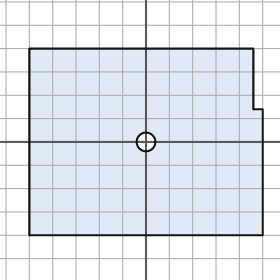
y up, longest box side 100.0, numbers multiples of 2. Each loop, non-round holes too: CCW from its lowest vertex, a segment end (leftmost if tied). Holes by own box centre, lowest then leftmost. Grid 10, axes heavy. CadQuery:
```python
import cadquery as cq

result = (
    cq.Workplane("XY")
    .moveTo(-50.0, -40.0)
    .lineTo(50.0, -40.0)
    .lineTo(50.0, 14.0)
    .lineTo(46.0, 14.0)
    .lineTo(46.0, 40.0)
    .lineTo(-50.0, 40.0)
    .close()
    .moveTo(0.0, 0.0)
    .circle(4.0)
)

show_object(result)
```